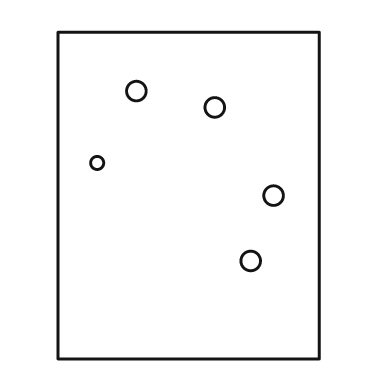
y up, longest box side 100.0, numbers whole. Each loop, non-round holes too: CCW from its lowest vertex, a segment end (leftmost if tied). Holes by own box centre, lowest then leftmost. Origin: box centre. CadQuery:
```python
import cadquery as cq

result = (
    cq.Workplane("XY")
    .moveTo(-40.0, -50.0)
    .lineTo(40.0, -50.0)
    .lineTo(40.0, 50.0)
    .lineTo(-40.0, 50.0)
    .close()
    .moveTo(19.0, -20.0)
    .circle(3.0)
    .moveTo(26.0, 0.0)
    .circle(3.0)
    .moveTo(-28.0, 10.0)
    .circle(2.0)
    .moveTo(8.0, 27.0)
    .circle(3.0)
    .moveTo(-16.0, 32.0)
    .circle(3.0)
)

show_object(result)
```